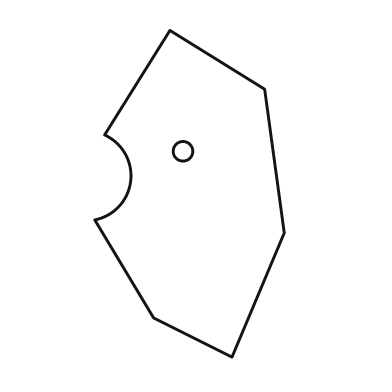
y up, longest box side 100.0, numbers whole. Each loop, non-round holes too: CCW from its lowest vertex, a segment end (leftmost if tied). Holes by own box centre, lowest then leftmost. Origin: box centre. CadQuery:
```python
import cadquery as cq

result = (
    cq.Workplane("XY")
    .moveTo(13.0, -50.0)
    .lineTo(29.0, -12.0)
    .lineTo(23.0, 32.0)
    .lineTo(-6.0, 50.0)
    .lineTo(-26.0, 18.0)
    .threePointArc((-18.0, 4.0), (-29.0, -8.0))
    .lineTo(-11.0, -38.0)
    .close()
    .moveTo(-2.0, 13.0)
    .circle(3.0)
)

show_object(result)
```